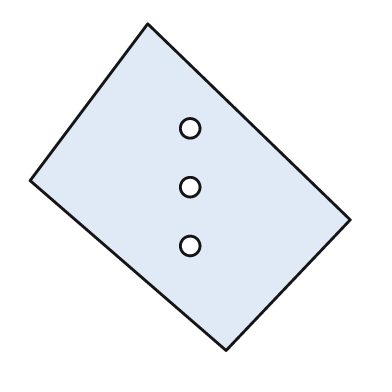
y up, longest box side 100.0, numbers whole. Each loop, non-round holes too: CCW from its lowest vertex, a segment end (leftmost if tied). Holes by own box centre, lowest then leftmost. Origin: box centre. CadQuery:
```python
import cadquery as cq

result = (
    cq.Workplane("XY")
    .moveTo(11.0, -50.0)
    .lineTo(49.0, -10.0)
    .lineTo(-13.0, 50.0)
    .lineTo(-49.0, 2.0)
    .close()
    .moveTo(0.0, -18.0)
    .circle(3.0)
    .moveTo(0.0, 0.0)
    .circle(3.0)
    .moveTo(0.0, 18.0)
    .circle(3.0)
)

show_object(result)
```